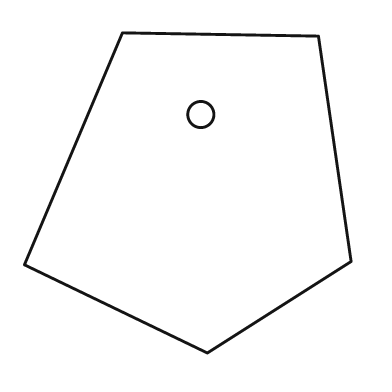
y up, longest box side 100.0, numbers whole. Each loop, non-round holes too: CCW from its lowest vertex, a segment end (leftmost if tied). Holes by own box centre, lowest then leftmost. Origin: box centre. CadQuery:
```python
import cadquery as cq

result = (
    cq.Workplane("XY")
    .moveTo(6.0, -49.0)
    .lineTo(50.0, -21.0)
    .lineTo(40.0, 48.0)
    .lineTo(-20.0, 49.0)
    .lineTo(-50.0, -22.0)
    .close()
    .moveTo(4.0, 24.0)
    .circle(4.0)
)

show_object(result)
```